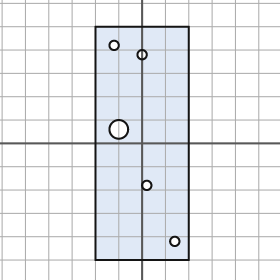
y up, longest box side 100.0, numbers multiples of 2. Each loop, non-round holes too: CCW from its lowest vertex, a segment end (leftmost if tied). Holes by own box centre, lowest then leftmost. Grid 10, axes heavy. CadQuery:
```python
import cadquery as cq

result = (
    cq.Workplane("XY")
    .moveTo(-20.0, -50.0)
    .lineTo(20.0, -50.0)
    .lineTo(20.0, 50.0)
    .lineTo(-20.0, 50.0)
    .close()
    .moveTo(14.0, -42.0)
    .circle(2.0)
    .moveTo(2.0, -18.0)
    .circle(2.0)
    .moveTo(-10.0, 6.0)
    .circle(4.0)
    .moveTo(0.0, 38.0)
    .circle(2.0)
    .moveTo(-12.0, 42.0)
    .circle(2.0)
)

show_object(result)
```